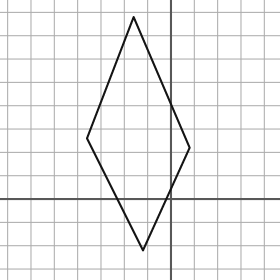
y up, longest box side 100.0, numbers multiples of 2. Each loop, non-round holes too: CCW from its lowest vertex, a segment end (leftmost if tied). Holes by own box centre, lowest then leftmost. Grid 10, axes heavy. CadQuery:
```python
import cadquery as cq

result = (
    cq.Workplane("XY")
    .moveTo(-12.0, -22.0)
    .lineTo(8.0, 22.0)
    .lineTo(-16.0, 78.0)
    .lineTo(-36.0, 26.0)
    .close()
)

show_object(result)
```